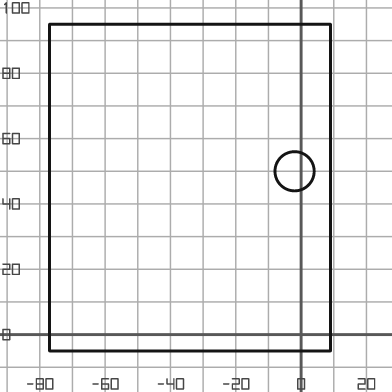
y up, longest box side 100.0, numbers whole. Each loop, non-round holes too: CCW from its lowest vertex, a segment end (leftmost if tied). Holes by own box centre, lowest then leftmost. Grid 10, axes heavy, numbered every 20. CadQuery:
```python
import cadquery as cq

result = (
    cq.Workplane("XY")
    .moveTo(-77.0, -5.0)
    .lineTo(9.0, -5.0)
    .lineTo(9.0, 95.0)
    .lineTo(-77.0, 95.0)
    .close()
    .moveTo(-2.0, 50.0)
    .circle(6.0)
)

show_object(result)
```